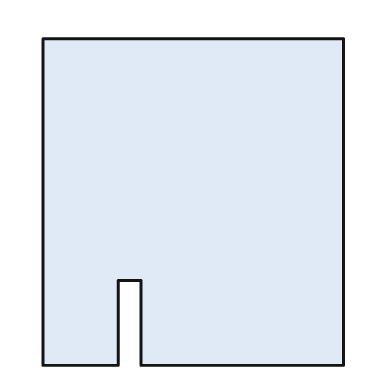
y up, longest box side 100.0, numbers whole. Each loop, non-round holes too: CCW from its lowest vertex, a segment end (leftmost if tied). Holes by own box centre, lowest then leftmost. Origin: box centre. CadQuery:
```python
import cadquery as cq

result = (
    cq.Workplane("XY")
    .moveTo(-46.0, -50.0)
    .lineTo(-23.0, -50.0)
    .lineTo(-23.0, -24.0)
    .lineTo(-16.0, -24.0)
    .lineTo(-16.0, -50.0)
    .lineTo(46.0, -50.0)
    .lineTo(46.0, 50.0)
    .lineTo(-46.0, 50.0)
    .close()
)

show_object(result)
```